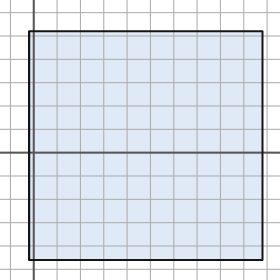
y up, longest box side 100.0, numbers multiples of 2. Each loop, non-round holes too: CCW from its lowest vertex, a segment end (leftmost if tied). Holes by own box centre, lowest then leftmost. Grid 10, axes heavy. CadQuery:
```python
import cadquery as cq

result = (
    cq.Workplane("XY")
    .moveTo(-2.0, -46.0)
    .lineTo(98.0, -46.0)
    .lineTo(98.0, 52.0)
    .lineTo(-2.0, 52.0)
    .close()
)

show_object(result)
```